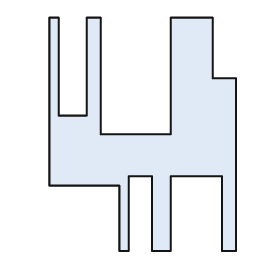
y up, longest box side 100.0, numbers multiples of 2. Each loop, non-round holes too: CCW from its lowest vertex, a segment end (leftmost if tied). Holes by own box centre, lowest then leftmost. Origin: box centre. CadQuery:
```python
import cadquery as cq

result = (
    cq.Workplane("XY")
    .moveTo(-10.0, -50.0)
    .lineTo(-6.0, -50.0)
    .lineTo(-6.0, -18.0)
    .lineTo(4.0, -18.0)
    .lineTo(4.0, -50.0)
    .lineTo(12.0, -50.0)
    .lineTo(12.0, -18.0)
    .lineTo(34.0, -18.0)
    .lineTo(34.0, -50.0)
    .lineTo(40.0, -50.0)
    .lineTo(40.0, 24.0)
    .lineTo(30.0, 24.0)
    .lineTo(30.0, 50.0)
    .lineTo(12.0, 50.0)
    .lineTo(12.0, 0.0)
    .lineTo(-18.0, 0.0)
    .lineTo(-18.0, 50.0)
    .lineTo(-24.0, 50.0)
    .lineTo(-24.0, 8.0)
    .lineTo(-36.0, 8.0)
    .lineTo(-36.0, 50.0)
    .lineTo(-40.0, 50.0)
    .lineTo(-40.0, -22.0)
    .lineTo(-10.0, -22.0)
    .close()
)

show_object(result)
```